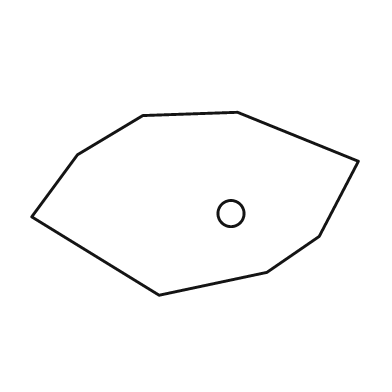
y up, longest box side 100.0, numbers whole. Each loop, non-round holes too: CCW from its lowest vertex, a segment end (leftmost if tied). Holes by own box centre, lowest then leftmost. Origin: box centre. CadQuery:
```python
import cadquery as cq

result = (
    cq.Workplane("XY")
    .moveTo(-11.0, -28.0)
    .lineTo(22.0, -21.0)
    .lineTo(38.0, -10.0)
    .lineTo(50.0, 13.0)
    .lineTo(13.0, 28.0)
    .lineTo(-16.0, 27.0)
    .lineTo(-36.0, 15.0)
    .lineTo(-50.0, -4.0)
    .close()
    .moveTo(11.0, -3.0)
    .circle(4.0)
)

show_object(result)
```